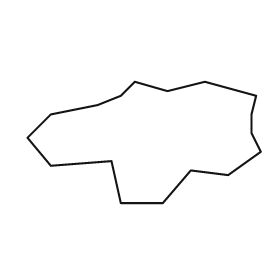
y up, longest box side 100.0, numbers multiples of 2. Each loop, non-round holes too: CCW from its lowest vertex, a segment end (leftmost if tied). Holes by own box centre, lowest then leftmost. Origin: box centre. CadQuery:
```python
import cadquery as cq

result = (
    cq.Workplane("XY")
    .moveTo(-10.0, -26.0)
    .lineTo(8.0, -26.0)
    .lineTo(20.0, -12.0)
    .lineTo(36.0, -14.0)
    .lineTo(50.0, -4.0)
    .lineTo(46.0, 4.0)
    .lineTo(46.0, 12.0)
    .lineTo(48.0, 20.0)
    .lineTo(26.0, 26.0)
    .lineTo(10.0, 22.0)
    .lineTo(-4.0, 26.0)
    .lineTo(-10.0, 20.0)
    .lineTo(-20.0, 16.0)
    .lineTo(-40.0, 12.0)
    .lineTo(-50.0, 2.0)
    .lineTo(-40.0, -10.0)
    .lineTo(-14.0, -8.0)
    .close()
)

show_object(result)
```